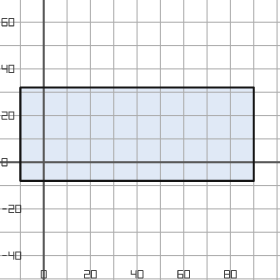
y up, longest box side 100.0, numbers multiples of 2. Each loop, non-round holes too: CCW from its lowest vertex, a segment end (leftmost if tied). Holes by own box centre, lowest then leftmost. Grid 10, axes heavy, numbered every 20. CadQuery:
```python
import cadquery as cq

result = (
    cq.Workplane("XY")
    .moveTo(-10.0, -8.0)
    .lineTo(90.0, -8.0)
    .lineTo(90.0, 32.0)
    .lineTo(-10.0, 32.0)
    .close()
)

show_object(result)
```